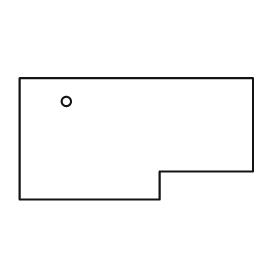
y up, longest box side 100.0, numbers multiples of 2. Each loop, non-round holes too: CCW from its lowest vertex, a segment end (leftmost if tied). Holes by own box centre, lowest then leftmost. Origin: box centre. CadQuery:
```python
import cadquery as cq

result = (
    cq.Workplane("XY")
    .moveTo(-50.0, -26.0)
    .lineTo(10.0, -26.0)
    .lineTo(10.0, -14.0)
    .lineTo(50.0, -14.0)
    .lineTo(50.0, 26.0)
    .lineTo(-50.0, 26.0)
    .close()
    .moveTo(-30.0, 16.0)
    .circle(2.0)
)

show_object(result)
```